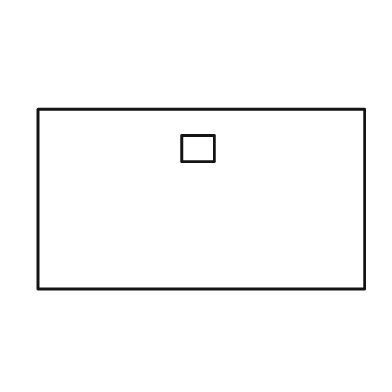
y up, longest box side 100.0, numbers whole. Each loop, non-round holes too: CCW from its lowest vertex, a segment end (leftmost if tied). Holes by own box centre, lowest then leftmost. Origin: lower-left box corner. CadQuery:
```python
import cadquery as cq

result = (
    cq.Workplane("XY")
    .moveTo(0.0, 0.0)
    .lineTo(100.0, 0.0)
    .lineTo(100.0, 55.0)
    .lineTo(0.0, 55.0)
    .close()
    .moveTo(44.0, 39.0)
    .lineTo(54.0, 39.0)
    .lineTo(54.0, 47.0)
    .lineTo(44.0, 47.0)
    .close()
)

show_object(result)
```